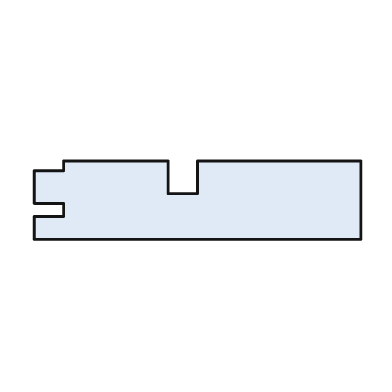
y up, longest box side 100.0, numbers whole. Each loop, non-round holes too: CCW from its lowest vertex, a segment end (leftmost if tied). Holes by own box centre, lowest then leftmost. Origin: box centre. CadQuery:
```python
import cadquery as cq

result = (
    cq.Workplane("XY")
    .moveTo(-50.0, -12.0)
    .lineTo(50.0, -12.0)
    .lineTo(50.0, 12.0)
    .lineTo(0.0, 12.0)
    .lineTo(0.0, 2.0)
    .lineTo(-9.0, 2.0)
    .lineTo(-9.0, 12.0)
    .lineTo(-41.0, 12.0)
    .lineTo(-41.0, 9.0)
    .lineTo(-50.0, 9.0)
    .lineTo(-50.0, -1.0)
    .lineTo(-41.0, -1.0)
    .lineTo(-41.0, -5.0)
    .lineTo(-50.0, -5.0)
    .close()
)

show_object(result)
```